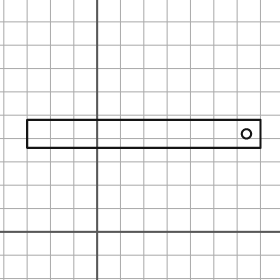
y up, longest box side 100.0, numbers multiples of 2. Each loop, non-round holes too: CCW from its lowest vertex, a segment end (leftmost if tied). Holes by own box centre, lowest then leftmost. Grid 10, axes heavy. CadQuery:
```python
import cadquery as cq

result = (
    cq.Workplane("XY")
    .moveTo(-30.0, 36.0)
    .lineTo(70.0, 36.0)
    .lineTo(70.0, 48.0)
    .lineTo(-30.0, 48.0)
    .close()
    .moveTo(64.0, 42.0)
    .circle(2.0)
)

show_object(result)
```